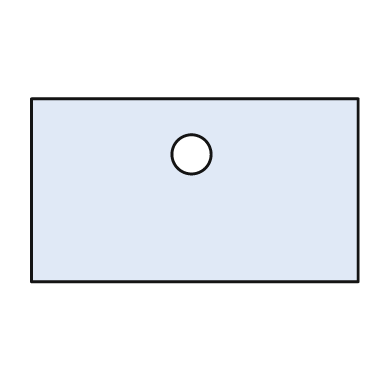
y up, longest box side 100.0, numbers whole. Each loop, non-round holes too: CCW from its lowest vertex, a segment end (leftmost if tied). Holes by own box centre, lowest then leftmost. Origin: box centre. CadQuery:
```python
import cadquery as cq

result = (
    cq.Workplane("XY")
    .moveTo(-50.0, -28.0)
    .lineTo(50.0, -28.0)
    .lineTo(50.0, 28.0)
    .lineTo(-50.0, 28.0)
    .close()
    .moveTo(-1.0, 11.0)
    .circle(6.0)
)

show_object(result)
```